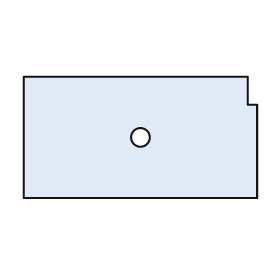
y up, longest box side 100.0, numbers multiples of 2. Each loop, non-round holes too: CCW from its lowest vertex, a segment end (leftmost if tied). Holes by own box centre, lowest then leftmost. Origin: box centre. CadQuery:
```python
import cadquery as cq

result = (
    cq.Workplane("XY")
    .moveTo(-50.0, -26.0)
    .lineTo(50.0, -26.0)
    .lineTo(50.0, 14.0)
    .lineTo(46.0, 14.0)
    .lineTo(46.0, 26.0)
    .lineTo(-50.0, 26.0)
    .close()
    .moveTo(0.0, 0.0)
    .circle(4.0)
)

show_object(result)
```